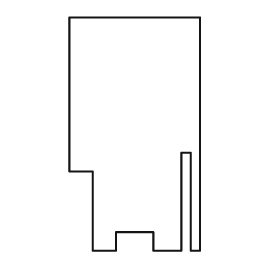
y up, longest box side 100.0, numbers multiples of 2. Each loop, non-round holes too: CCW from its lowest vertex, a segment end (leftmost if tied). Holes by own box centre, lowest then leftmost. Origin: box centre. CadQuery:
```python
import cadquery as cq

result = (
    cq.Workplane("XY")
    .moveTo(-18.0, -50.0)
    .lineTo(-8.0, -50.0)
    .lineTo(-8.0, -42.0)
    .lineTo(8.0, -42.0)
    .lineTo(8.0, -50.0)
    .lineTo(20.0, -50.0)
    .lineTo(20.0, -8.0)
    .lineTo(24.0, -8.0)
    .lineTo(24.0, -50.0)
    .lineTo(28.0, -50.0)
    .lineTo(28.0, 50.0)
    .lineTo(-28.0, 50.0)
    .lineTo(-28.0, -16.0)
    .lineTo(-18.0, -16.0)
    .close()
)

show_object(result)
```